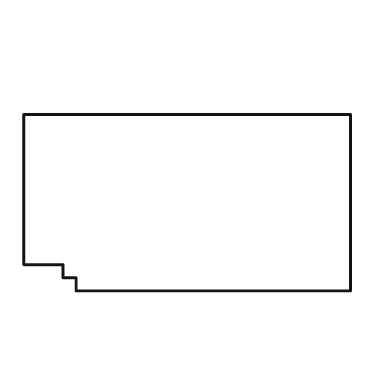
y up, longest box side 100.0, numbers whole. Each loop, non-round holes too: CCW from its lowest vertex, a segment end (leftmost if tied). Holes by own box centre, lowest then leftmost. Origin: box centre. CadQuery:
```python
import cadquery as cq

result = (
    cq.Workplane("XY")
    .moveTo(-34.0, -27.0)
    .lineTo(50.0, -27.0)
    .lineTo(50.0, 27.0)
    .lineTo(-50.0, 27.0)
    .lineTo(-50.0, -19.0)
    .lineTo(-38.0, -19.0)
    .lineTo(-38.0, -23.0)
    .lineTo(-34.0, -23.0)
    .close()
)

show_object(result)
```